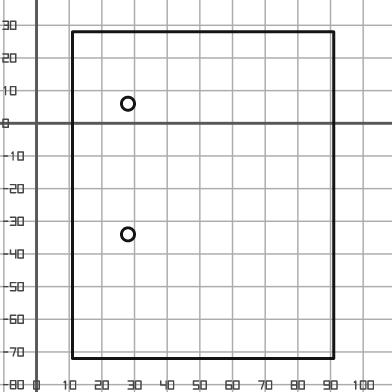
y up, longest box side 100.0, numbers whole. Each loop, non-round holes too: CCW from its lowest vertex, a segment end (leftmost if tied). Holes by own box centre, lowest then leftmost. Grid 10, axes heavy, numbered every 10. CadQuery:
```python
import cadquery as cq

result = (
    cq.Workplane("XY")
    .moveTo(11.0, -72.0)
    .lineTo(91.0, -72.0)
    .lineTo(91.0, 28.0)
    .lineTo(11.0, 28.0)
    .close()
    .moveTo(28.0, -34.0)
    .circle(2.0)
    .moveTo(28.0, 6.0)
    .circle(2.0)
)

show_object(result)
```